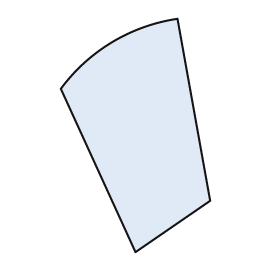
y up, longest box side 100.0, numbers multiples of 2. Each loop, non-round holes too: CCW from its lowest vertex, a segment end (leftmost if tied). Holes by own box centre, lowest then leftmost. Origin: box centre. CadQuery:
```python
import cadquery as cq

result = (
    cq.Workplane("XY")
    .moveTo(0.0, -50.0)
    .lineTo(32.0, -28.0)
    .lineTo(18.0, 50.0)
    .threePointArc((-10.0, 40.0), (-32.0, 20.0))
    .close()
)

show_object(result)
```